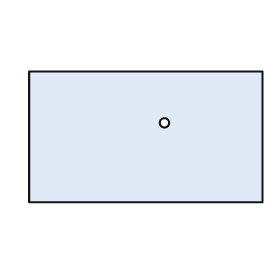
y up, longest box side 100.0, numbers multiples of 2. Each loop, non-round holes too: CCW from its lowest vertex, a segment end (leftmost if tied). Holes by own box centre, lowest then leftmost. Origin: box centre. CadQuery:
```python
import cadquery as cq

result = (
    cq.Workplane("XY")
    .moveTo(-50.0, -28.0)
    .lineTo(50.0, -28.0)
    .lineTo(50.0, 28.0)
    .lineTo(-50.0, 28.0)
    .close()
    .moveTo(8.0, 6.0)
    .circle(2.0)
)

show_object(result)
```